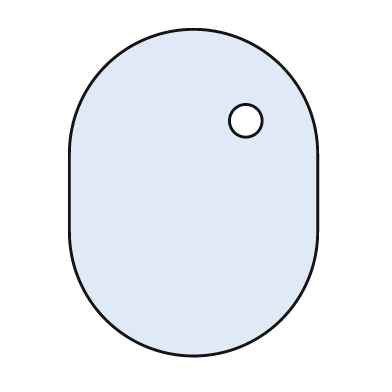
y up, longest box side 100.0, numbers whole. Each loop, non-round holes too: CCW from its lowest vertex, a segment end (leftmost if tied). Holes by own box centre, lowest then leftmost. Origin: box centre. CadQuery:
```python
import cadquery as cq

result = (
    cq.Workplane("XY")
    .moveTo(-38.0, -12.0)
    .threePointArc((0.0, -50.0), (38.0, -12.0))
    .lineTo(38.0, 12.0)
    .threePointArc((0.0, 50.0), (-38.0, 12.0))
    .close()
    .moveTo(16.0, 22.0)
    .circle(5.0)
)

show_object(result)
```